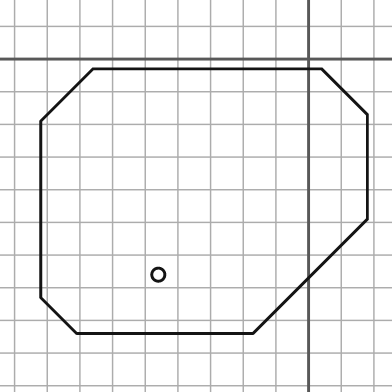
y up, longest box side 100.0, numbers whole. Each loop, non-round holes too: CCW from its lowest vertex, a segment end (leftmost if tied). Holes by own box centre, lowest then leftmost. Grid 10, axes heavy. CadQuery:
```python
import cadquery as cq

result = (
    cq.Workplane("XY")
    .moveTo(-71.0, -84.0)
    .lineTo(-17.0, -84.0)
    .lineTo(18.0, -49.0)
    .lineTo(18.0, -17.0)
    .lineTo(4.0, -3.0)
    .lineTo(-66.0, -3.0)
    .lineTo(-82.0, -19.0)
    .lineTo(-82.0, -73.0)
    .close()
    .moveTo(-46.0, -66.0)
    .circle(2.0)
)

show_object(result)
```